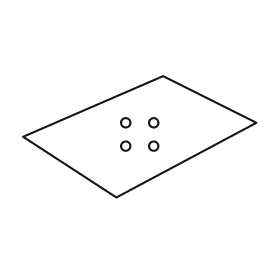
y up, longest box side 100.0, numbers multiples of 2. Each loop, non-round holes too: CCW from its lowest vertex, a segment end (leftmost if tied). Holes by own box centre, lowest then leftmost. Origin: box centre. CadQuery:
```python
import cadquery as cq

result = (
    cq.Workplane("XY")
    .moveTo(-10.0, -26.0)
    .lineTo(50.0, 6.0)
    .lineTo(10.0, 26.0)
    .lineTo(-50.0, 0.0)
    .close()
    .moveTo(-6.0, -4.0)
    .circle(2.0)
    .moveTo(6.0, -4.0)
    .circle(2.0)
    .moveTo(-6.0, 6.0)
    .circle(2.0)
    .moveTo(6.0, 6.0)
    .circle(2.0)
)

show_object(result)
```